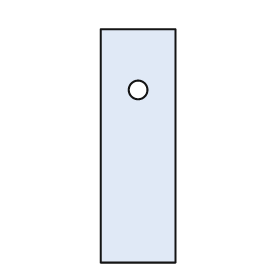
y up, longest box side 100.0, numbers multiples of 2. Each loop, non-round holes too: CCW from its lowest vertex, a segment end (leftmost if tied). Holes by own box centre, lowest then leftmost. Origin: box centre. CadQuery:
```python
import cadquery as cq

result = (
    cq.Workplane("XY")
    .moveTo(-16.0, -50.0)
    .lineTo(16.0, -50.0)
    .lineTo(16.0, 50.0)
    .lineTo(-16.0, 50.0)
    .close()
    .moveTo(0.0, 24.0)
    .circle(4.0)
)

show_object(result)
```